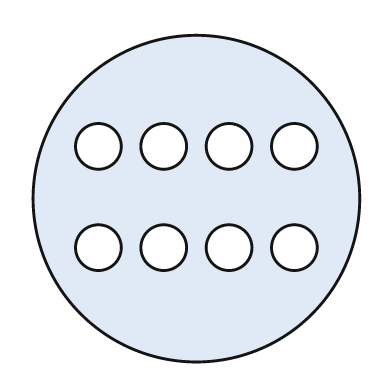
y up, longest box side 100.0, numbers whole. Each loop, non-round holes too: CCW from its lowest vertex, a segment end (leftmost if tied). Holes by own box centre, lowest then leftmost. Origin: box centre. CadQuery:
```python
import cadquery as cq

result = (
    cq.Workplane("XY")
    .moveTo(0.0, 0.0)
    .circle(50.0)
    .moveTo(-30.0, -15.0)
    .circle(7.0)
    .moveTo(-10.0, -15.0)
    .circle(7.0)
    .moveTo(10.0, -15.0)
    .circle(7.0)
    .moveTo(30.0, -15.0)
    .circle(7.0)
    .moveTo(-30.0, 16.0)
    .circle(7.0)
    .moveTo(-10.0, 16.0)
    .circle(7.0)
    .moveTo(10.0, 16.0)
    .circle(7.0)
    .moveTo(30.0, 16.0)
    .circle(7.0)
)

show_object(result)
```